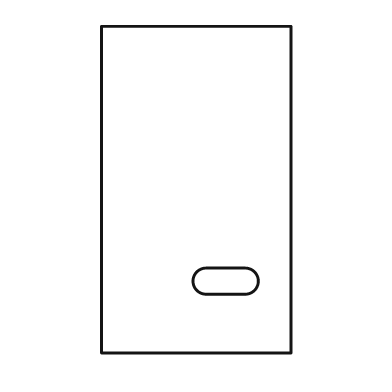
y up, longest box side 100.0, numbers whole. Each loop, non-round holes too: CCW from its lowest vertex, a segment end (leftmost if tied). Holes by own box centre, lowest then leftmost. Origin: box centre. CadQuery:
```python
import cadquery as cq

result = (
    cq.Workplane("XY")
    .moveTo(-29.0, -50.0)
    .lineTo(29.0, -50.0)
    .lineTo(29.0, 50.0)
    .lineTo(-29.0, 50.0)
    .close()
    .moveTo(3.0, -32.0)
    .lineTo(15.0, -32.0)
    .threePointArc((19.0, -28.0), (15.0, -24.0))
    .lineTo(3.0, -24.0)
    .threePointArc((-1.0, -28.0), (3.0, -32.0))
    .close()
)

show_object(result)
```